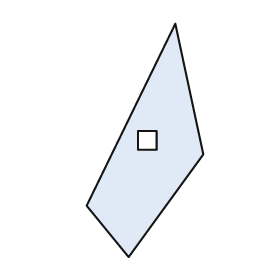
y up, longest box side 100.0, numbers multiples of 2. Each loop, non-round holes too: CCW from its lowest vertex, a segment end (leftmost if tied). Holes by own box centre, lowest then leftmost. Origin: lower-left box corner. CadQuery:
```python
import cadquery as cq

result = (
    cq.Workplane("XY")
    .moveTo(18.0, 0.0)
    .lineTo(50.0, 44.0)
    .lineTo(38.0, 100.0)
    .lineTo(0.0, 22.0)
    .close()
    .moveTo(22.0, 46.0)
    .lineTo(30.0, 46.0)
    .lineTo(30.0, 54.0)
    .lineTo(22.0, 54.0)
    .close()
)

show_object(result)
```